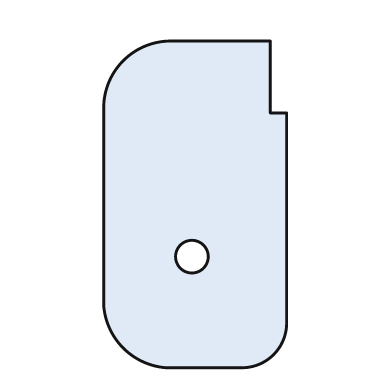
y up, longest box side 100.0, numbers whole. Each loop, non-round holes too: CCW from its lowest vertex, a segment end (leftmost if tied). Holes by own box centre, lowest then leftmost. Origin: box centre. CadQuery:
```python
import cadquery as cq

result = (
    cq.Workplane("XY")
    .moveTo(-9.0, -50.0)
    .lineTo(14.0, -50.0)
    .threePointArc((24.0, -46.0), (28.0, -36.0))
    .lineTo(28.0, 28.0)
    .lineTo(23.0, 28.0)
    .lineTo(23.0, 50.0)
    .lineTo(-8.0, 50.0)
    .threePointArc((-22.0, 44.0), (-28.0, 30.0))
    .lineTo(-28.0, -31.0)
    .threePointArc((-22.0, -44.0), (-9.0, -50.0))
    .close()
    .moveTo(-1.0, -16.0)
    .circle(5.0)
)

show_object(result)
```